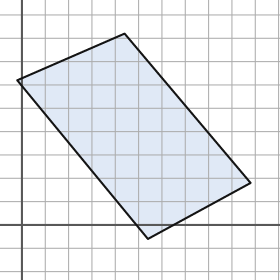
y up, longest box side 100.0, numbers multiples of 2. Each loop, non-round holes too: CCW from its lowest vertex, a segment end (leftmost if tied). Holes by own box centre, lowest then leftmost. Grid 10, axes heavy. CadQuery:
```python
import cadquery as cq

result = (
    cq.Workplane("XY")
    .moveTo(54.0, -6.0)
    .lineTo(98.0, 18.0)
    .lineTo(44.0, 82.0)
    .lineTo(-2.0, 62.0)
    .close()
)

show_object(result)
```